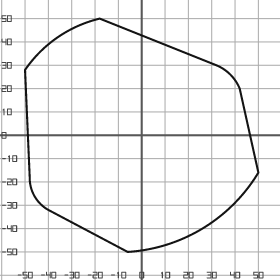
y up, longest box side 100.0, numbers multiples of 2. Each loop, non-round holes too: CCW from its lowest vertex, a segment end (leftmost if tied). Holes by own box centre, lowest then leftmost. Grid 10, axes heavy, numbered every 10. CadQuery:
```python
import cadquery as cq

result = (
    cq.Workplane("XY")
    .moveTo(-6.0, -50.0)
    .threePointArc((26.0, -40.0), (50.0, -16.0))
    .lineTo(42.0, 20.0)
    .threePointArc((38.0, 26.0), (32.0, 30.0))
    .lineTo(-18.0, 50.0)
    .threePointArc((-36.0, 42.0), (-50.0, 28.0))
    .lineTo(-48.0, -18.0)
    .threePointArc((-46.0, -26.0), (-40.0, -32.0))
    .close()
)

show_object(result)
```